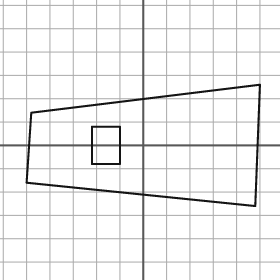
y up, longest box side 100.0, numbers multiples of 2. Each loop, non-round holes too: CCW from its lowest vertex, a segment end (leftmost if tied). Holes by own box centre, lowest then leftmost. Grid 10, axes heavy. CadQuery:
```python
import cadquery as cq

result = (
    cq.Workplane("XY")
    .moveTo(48.0, -26.0)
    .lineTo(50.0, 26.0)
    .lineTo(-48.0, 14.0)
    .lineTo(-50.0, -16.0)
    .close()
    .moveTo(-22.0, -8.0)
    .lineTo(-10.0, -8.0)
    .lineTo(-10.0, 8.0)
    .lineTo(-22.0, 8.0)
    .close()
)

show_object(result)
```